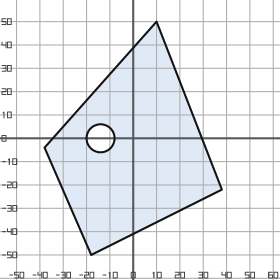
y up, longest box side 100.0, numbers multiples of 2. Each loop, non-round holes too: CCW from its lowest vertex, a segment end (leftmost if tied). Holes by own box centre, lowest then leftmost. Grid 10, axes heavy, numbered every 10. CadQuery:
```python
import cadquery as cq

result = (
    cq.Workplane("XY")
    .moveTo(-18.0, -50.0)
    .lineTo(38.0, -22.0)
    .lineTo(10.0, 50.0)
    .lineTo(-38.0, -4.0)
    .close()
    .moveTo(-14.0, 0.0)
    .circle(6.0)
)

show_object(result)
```